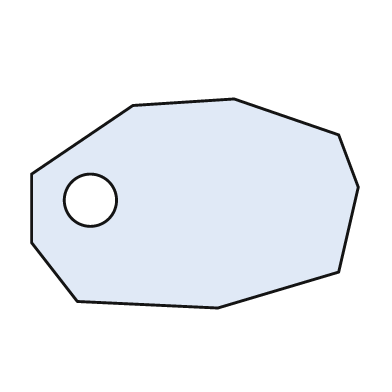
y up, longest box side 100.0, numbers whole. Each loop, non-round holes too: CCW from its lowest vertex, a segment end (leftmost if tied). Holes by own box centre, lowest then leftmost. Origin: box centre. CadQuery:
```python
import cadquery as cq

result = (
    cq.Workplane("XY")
    .moveTo(7.0, -32.0)
    .lineTo(44.0, -21.0)
    .lineTo(50.0, 5.0)
    .lineTo(44.0, 21.0)
    .lineTo(12.0, 32.0)
    .lineTo(-19.0, 30.0)
    .lineTo(-50.0, 9.0)
    .lineTo(-50.0, -12.0)
    .lineTo(-36.0, -30.0)
    .close()
    .moveTo(-32.0, 1.0)
    .circle(8.0)
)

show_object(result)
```